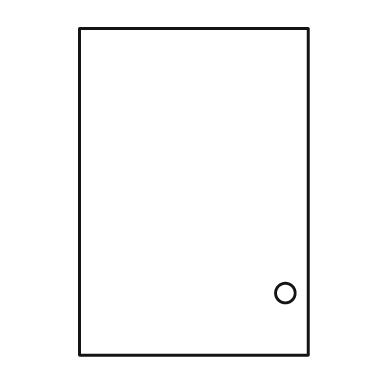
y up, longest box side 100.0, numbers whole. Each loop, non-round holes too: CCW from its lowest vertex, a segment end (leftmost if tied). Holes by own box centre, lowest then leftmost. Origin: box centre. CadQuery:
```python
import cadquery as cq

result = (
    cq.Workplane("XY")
    .moveTo(-35.0, -50.0)
    .lineTo(35.0, -50.0)
    .lineTo(35.0, 50.0)
    .lineTo(-35.0, 50.0)
    .close()
    .moveTo(28.0, -31.0)
    .circle(3.0)
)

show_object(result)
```